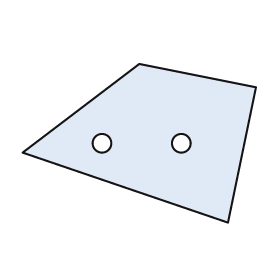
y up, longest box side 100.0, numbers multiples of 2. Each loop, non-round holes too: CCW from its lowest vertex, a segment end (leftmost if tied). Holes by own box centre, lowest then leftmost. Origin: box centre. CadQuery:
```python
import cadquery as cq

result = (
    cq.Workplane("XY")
    .moveTo(38.0, -34.0)
    .lineTo(50.0, 24.0)
    .lineTo(0.0, 34.0)
    .lineTo(-50.0, -4.0)
    .close()
    .moveTo(-16.0, 0.0)
    .circle(4.0)
    .moveTo(18.0, 0.0)
    .circle(4.0)
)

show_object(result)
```